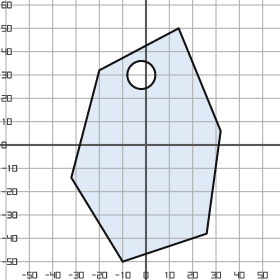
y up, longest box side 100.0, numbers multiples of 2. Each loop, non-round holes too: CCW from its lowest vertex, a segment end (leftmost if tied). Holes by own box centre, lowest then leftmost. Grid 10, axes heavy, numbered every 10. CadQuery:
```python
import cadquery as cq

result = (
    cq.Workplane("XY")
    .moveTo(-10.0, -50.0)
    .lineTo(26.0, -38.0)
    .lineTo(32.0, 6.0)
    .lineTo(14.0, 50.0)
    .lineTo(-20.0, 32.0)
    .lineTo(-32.0, -14.0)
    .close()
    .moveTo(-2.0, 30.0)
    .circle(6.0)
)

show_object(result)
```